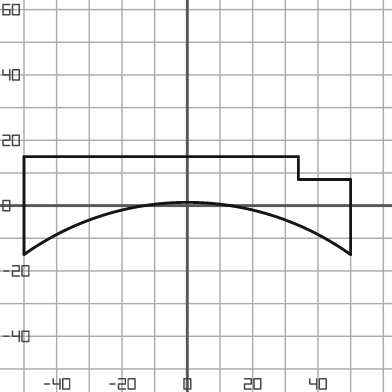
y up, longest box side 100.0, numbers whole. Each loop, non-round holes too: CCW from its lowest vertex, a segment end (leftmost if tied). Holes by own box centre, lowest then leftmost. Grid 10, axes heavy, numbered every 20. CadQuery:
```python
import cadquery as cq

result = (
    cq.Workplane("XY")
    .moveTo(-50.0, -15.0)
    .threePointArc((0.0, 1.0), (50.0, -15.0))
    .lineTo(50.0, 8.0)
    .lineTo(34.0, 8.0)
    .lineTo(34.0, 15.0)
    .lineTo(-50.0, 15.0)
    .close()
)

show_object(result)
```